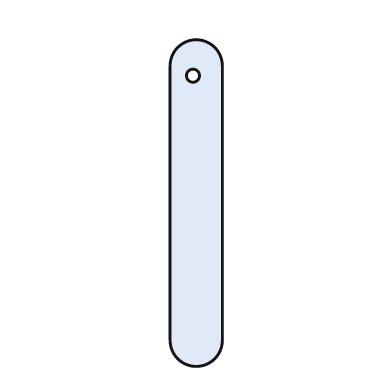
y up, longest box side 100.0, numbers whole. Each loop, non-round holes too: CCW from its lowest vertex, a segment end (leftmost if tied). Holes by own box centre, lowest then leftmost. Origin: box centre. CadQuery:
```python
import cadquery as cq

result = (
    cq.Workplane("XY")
    .moveTo(-8.0, -42.0)
    .threePointArc((0.0, -50.0), (8.0, -42.0))
    .lineTo(8.0, 42.0)
    .threePointArc((0.0, 50.0), (-8.0, 42.0))
    .close()
    .moveTo(-1.0, 39.0)
    .circle(2.0)
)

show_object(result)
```